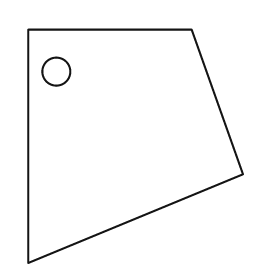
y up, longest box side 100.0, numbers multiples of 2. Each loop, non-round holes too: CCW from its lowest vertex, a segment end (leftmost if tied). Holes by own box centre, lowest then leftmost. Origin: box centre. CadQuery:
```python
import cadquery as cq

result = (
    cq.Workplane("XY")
    .moveTo(-46.0, -50.0)
    .lineTo(46.0, -12.0)
    .lineTo(24.0, 50.0)
    .lineTo(-46.0, 50.0)
    .close()
    .moveTo(-34.0, 32.0)
    .circle(6.0)
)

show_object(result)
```